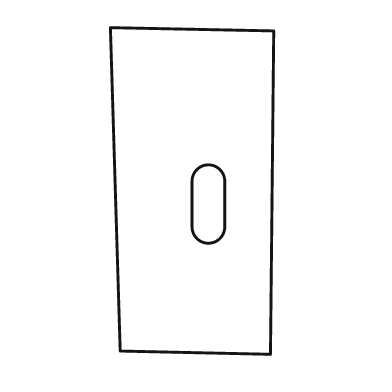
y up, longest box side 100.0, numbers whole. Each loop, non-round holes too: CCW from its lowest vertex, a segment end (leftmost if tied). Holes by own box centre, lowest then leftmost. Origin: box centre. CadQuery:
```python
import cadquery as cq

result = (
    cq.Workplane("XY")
    .moveTo(24.0, -50.0)
    .lineTo(25.0, 49.0)
    .lineTo(-25.0, 50.0)
    .lineTo(-22.0, -49.0)
    .close()
    .moveTo(0.0, -11.0)
    .threePointArc((5.0, -16.0), (10.0, -11.0))
    .lineTo(10.0, 3.0)
    .threePointArc((5.0, 8.0), (0.0, 3.0))
    .close()
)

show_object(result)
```